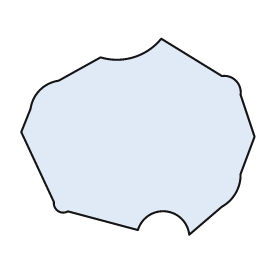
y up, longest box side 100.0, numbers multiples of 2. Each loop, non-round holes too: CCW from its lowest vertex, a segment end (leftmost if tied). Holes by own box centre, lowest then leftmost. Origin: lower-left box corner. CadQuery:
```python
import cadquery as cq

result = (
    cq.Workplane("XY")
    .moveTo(72.0, 0.0)
    .lineTo(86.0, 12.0)
    .threePointArc((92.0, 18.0), (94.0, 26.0))
    .lineTo(100.0, 42.0)
    .lineTo(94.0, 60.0)
    .threePointArc((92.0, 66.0), (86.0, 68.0))
    .lineTo(60.0, 84.0)
    .threePointArc((48.0, 76.0), (34.0, 76.0))
    .lineTo(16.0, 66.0)
    .threePointArc((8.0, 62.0), (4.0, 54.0))
    .lineTo(0.0, 44.0)
    .lineTo(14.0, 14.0)
    .threePointArc((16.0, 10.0), (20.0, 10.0))
    .lineTo(50.0, 2.0)
    .threePointArc((62.0, 10.0), (72.0, 0.0))
    .close()
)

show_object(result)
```